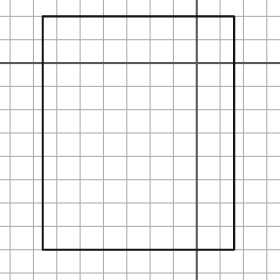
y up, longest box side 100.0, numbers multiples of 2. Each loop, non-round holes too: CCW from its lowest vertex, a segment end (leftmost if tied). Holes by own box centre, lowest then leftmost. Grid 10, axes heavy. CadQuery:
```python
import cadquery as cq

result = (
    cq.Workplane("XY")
    .moveTo(-66.0, -80.0)
    .lineTo(16.0, -80.0)
    .lineTo(16.0, 20.0)
    .lineTo(-66.0, 20.0)
    .close()
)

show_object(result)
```